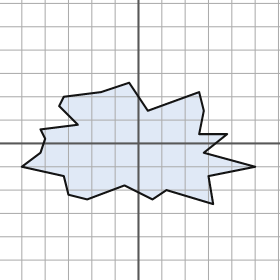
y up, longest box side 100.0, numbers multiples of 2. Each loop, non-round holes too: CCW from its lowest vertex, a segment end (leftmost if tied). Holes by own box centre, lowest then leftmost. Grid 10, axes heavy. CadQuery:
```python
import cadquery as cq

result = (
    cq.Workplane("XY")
    .moveTo(32.0, -26.0)
    .lineTo(30.0, -14.0)
    .lineTo(50.0, -10.0)
    .lineTo(28.0, -4.0)
    .lineTo(38.0, 4.0)
    .lineTo(26.0, 4.0)
    .lineTo(28.0, 14.0)
    .lineTo(26.0, 22.0)
    .lineTo(4.0, 14.0)
    .lineTo(-4.0, 26.0)
    .lineTo(-16.0, 22.0)
    .lineTo(-32.0, 20.0)
    .lineTo(-34.0, 16.0)
    .lineTo(-26.0, 8.0)
    .lineTo(-42.0, 6.0)
    .lineTo(-40.0, 2.0)
    .lineTo(-42.0, -4.0)
    .lineTo(-50.0, -10.0)
    .lineTo(-32.0, -14.0)
    .lineTo(-30.0, -22.0)
    .lineTo(-22.0, -24.0)
    .lineTo(-6.0, -18.0)
    .lineTo(6.0, -24.0)
    .lineTo(12.0, -20.0)
    .close()
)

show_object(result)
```